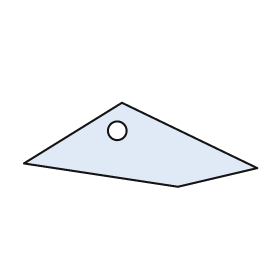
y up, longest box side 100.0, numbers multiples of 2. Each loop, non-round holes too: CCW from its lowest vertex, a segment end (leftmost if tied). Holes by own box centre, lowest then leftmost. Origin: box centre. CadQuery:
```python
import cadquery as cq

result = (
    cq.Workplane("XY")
    .moveTo(16.0, -18.0)
    .lineTo(50.0, -10.0)
    .lineTo(-8.0, 18.0)
    .lineTo(-50.0, -8.0)
    .close()
    .moveTo(-10.0, 6.0)
    .circle(4.0)
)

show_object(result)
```